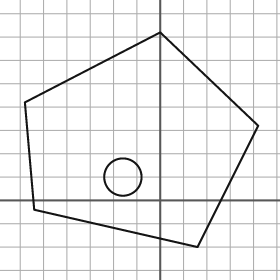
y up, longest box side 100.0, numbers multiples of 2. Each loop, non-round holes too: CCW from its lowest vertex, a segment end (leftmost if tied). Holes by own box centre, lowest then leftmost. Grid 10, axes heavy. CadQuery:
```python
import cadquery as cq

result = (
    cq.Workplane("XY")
    .moveTo(16.0, -20.0)
    .lineTo(42.0, 32.0)
    .lineTo(0.0, 72.0)
    .lineTo(-58.0, 42.0)
    .lineTo(-54.0, -4.0)
    .close()
    .moveTo(-16.0, 10.0)
    .circle(8.0)
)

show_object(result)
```